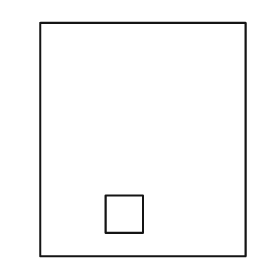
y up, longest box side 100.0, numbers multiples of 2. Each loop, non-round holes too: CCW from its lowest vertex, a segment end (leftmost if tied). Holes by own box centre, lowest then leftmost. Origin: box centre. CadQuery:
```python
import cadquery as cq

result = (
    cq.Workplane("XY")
    .moveTo(-44.0, -50.0)
    .lineTo(44.0, -50.0)
    .lineTo(44.0, 50.0)
    .lineTo(-44.0, 50.0)
    .close()
    .moveTo(-16.0, -40.0)
    .lineTo(0.0, -40.0)
    .lineTo(0.0, -24.0)
    .lineTo(-16.0, -24.0)
    .close()
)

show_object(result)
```